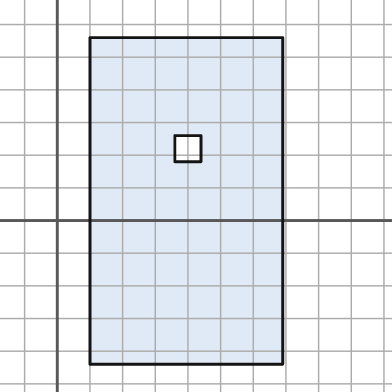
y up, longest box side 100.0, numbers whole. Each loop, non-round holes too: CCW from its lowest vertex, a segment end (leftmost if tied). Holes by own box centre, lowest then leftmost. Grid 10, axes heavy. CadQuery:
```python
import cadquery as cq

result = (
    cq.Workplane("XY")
    .moveTo(10.0, -44.0)
    .lineTo(69.0, -44.0)
    .lineTo(69.0, 56.0)
    .lineTo(10.0, 56.0)
    .close()
    .moveTo(36.0, 18.0)
    .lineTo(44.0, 18.0)
    .lineTo(44.0, 26.0)
    .lineTo(36.0, 26.0)
    .close()
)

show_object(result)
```